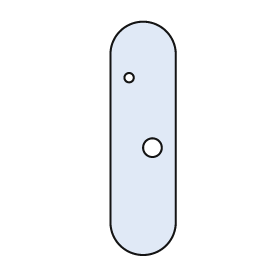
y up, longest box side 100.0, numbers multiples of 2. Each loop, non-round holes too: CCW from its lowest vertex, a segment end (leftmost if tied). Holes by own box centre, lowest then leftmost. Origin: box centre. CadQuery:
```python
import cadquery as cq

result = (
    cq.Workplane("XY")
    .moveTo(-14.0, -36.0)
    .threePointArc((0.0, -50.0), (14.0, -36.0))
    .lineTo(14.0, 36.0)
    .threePointArc((0.0, 50.0), (-14.0, 36.0))
    .close()
    .moveTo(4.0, -4.0)
    .circle(4.0)
    .moveTo(-6.0, 26.0)
    .circle(2.0)
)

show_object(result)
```